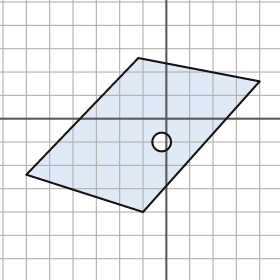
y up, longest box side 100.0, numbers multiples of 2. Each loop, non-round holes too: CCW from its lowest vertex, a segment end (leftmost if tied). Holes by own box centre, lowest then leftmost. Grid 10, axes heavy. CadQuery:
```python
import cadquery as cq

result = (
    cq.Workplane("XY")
    .moveTo(-10.0, -40.0)
    .lineTo(40.0, 16.0)
    .lineTo(-12.0, 26.0)
    .lineTo(-60.0, -24.0)
    .close()
    .moveTo(-2.0, -10.0)
    .circle(4.0)
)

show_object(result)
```